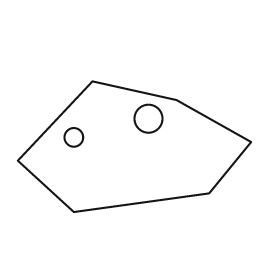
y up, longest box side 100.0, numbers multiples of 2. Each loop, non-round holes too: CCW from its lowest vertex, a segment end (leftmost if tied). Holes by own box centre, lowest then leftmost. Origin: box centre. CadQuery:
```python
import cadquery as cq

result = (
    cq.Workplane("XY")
    .moveTo(-26.0, -28.0)
    .lineTo(32.0, -20.0)
    .lineTo(50.0, 2.0)
    .lineTo(18.0, 20.0)
    .lineTo(-18.0, 28.0)
    .lineTo(-50.0, -6.0)
    .close()
    .moveTo(-26.0, 4.0)
    .circle(4.0)
    .moveTo(6.0, 12.0)
    .circle(6.0)
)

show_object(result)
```